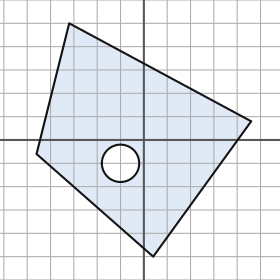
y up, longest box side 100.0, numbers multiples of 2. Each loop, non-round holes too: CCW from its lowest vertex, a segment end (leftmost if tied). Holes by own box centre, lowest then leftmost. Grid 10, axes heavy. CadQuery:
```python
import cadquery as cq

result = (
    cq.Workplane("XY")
    .moveTo(4.0, -50.0)
    .lineTo(46.0, 8.0)
    .lineTo(-32.0, 50.0)
    .lineTo(-46.0, -6.0)
    .close()
    .moveTo(-10.0, -10.0)
    .circle(8.0)
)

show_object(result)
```